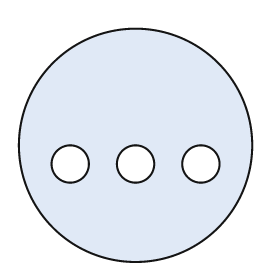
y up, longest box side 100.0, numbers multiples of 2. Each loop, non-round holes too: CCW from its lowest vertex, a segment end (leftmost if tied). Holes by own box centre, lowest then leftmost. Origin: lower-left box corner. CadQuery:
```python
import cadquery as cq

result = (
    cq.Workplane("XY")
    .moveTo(50.0, 50.0)
    .circle(50.0)
    .moveTo(22.0, 42.0)
    .circle(8.0)
    .moveTo(50.0, 42.0)
    .circle(8.0)
    .moveTo(78.0, 42.0)
    .circle(8.0)
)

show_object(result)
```